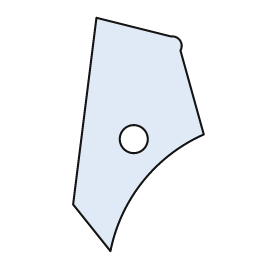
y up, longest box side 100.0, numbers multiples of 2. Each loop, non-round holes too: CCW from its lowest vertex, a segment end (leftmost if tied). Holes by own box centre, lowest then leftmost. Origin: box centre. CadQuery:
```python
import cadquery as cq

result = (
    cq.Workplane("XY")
    .moveTo(-12.0, -50.0)
    .threePointArc((2.0, -20.0), (28.0, 0.0))
    .lineTo(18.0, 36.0)
    .threePointArc((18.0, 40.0), (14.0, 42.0))
    .lineTo(-18.0, 50.0)
    .lineTo(-28.0, -30.0)
    .close()
    .moveTo(-2.0, -2.0)
    .circle(6.0)
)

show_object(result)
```